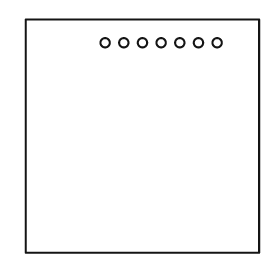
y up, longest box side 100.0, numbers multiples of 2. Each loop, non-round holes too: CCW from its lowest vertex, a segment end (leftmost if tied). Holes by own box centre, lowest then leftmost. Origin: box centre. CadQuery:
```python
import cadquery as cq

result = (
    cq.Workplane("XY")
    .moveTo(-50.0, -50.0)
    .lineTo(50.0, -50.0)
    .lineTo(50.0, 50.0)
    .lineTo(-50.0, 50.0)
    .close()
    .moveTo(-16.0, 40.0)
    .circle(2.0)
    .moveTo(-8.0, 40.0)
    .circle(2.0)
    .moveTo(0.0, 40.0)
    .circle(2.0)
    .moveTo(8.0, 40.0)
    .circle(2.0)
    .moveTo(16.0, 40.0)
    .circle(2.0)
    .moveTo(24.0, 40.0)
    .circle(2.0)
    .moveTo(32.0, 40.0)
    .circle(2.0)
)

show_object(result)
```